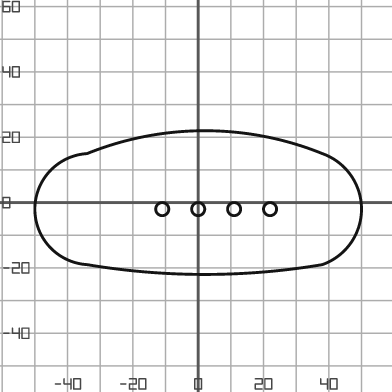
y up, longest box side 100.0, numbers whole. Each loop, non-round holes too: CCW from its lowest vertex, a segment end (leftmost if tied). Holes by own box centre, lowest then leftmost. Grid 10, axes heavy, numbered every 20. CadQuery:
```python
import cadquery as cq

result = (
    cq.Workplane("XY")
    .moveTo(-34.0, -19.0)
    .threePointArc((2.0, -22.0), (38.0, -19.0))
    .threePointArc((50.0, -2.0), (38.0, 15.0))
    .threePointArc((2.0, 22.0), (-34.0, 15.0))
    .threePointArc((-50.0, -2.0), (-34.0, -19.0))
    .close()
    .moveTo(-11.0, -2.0)
    .circle(2.0)
    .moveTo(0.0, -2.0)
    .circle(2.0)
    .moveTo(11.0, -2.0)
    .circle(2.0)
    .moveTo(22.0, -2.0)
    .circle(2.0)
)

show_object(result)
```